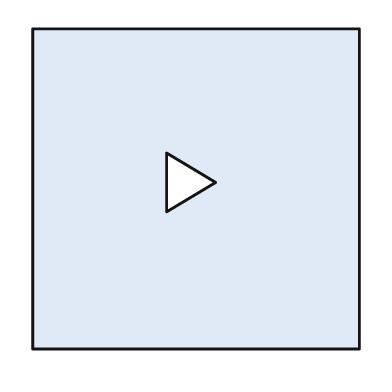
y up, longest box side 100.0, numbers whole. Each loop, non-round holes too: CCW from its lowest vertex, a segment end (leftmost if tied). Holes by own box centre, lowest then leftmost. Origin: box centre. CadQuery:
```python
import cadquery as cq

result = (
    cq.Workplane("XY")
    .moveTo(-50.0, -49.0)
    .lineTo(50.0, -49.0)
    .lineTo(50.0, 49.0)
    .lineTo(-50.0, 49.0)
    .close()
    .moveTo(-9.0, -7.0)
    .lineTo(6.0, 2.0)
    .lineTo(-9.0, 11.0)
    .close()
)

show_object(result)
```